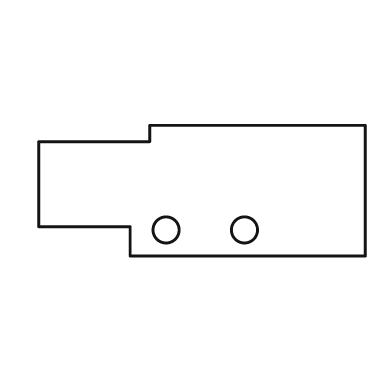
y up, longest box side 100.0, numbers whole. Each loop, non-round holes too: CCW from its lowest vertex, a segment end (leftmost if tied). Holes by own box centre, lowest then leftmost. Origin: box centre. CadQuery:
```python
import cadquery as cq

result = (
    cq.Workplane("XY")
    .moveTo(-22.0, -20.0)
    .lineTo(50.0, -20.0)
    .lineTo(50.0, 20.0)
    .lineTo(-16.0, 20.0)
    .lineTo(-16.0, 15.0)
    .lineTo(-50.0, 15.0)
    .lineTo(-50.0, -11.0)
    .lineTo(-22.0, -11.0)
    .close()
    .moveTo(-11.0, -12.0)
    .circle(4.0)
    .moveTo(13.0, -12.0)
    .circle(4.0)
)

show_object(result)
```